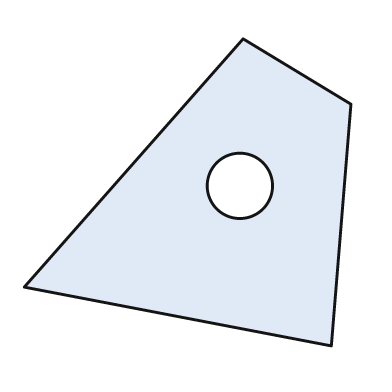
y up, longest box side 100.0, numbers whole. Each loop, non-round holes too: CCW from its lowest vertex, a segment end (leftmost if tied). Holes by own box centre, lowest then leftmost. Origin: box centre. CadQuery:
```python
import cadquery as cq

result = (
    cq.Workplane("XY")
    .moveTo(44.0, -47.0)
    .lineTo(50.0, 27.0)
    .lineTo(17.0, 47.0)
    .lineTo(-50.0, -29.0)
    .close()
    .moveTo(16.0, 2.0)
    .circle(10.0)
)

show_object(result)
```